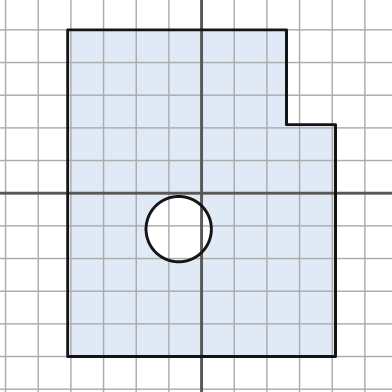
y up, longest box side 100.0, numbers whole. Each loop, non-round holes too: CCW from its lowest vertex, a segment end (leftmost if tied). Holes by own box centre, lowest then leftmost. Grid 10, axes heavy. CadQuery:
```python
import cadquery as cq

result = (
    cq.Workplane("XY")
    .moveTo(-41.0, -50.0)
    .lineTo(41.0, -50.0)
    .lineTo(41.0, 21.0)
    .lineTo(26.0, 21.0)
    .lineTo(26.0, 50.0)
    .lineTo(-41.0, 50.0)
    .close()
    .moveTo(-7.0, -11.0)
    .circle(10.0)
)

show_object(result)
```